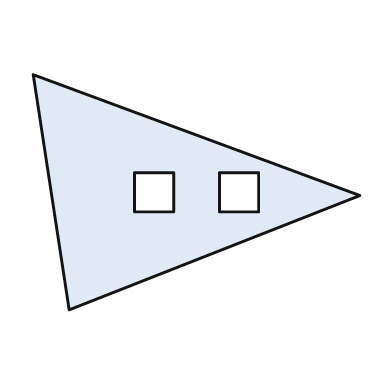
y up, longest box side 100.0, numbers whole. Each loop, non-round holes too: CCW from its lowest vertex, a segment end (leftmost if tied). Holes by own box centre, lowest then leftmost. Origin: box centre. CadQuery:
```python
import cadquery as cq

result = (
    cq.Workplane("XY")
    .moveTo(-39.0, -36.0)
    .lineTo(50.0, -1.0)
    .lineTo(-50.0, 36.0)
    .close()
    .moveTo(-19.0, -6.0)
    .lineTo(-7.0, -6.0)
    .lineTo(-7.0, 6.0)
    .lineTo(-19.0, 6.0)
    .close()
    .moveTo(7.0, -6.0)
    .lineTo(19.0, -6.0)
    .lineTo(19.0, 6.0)
    .lineTo(7.0, 6.0)
    .close()
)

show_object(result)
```